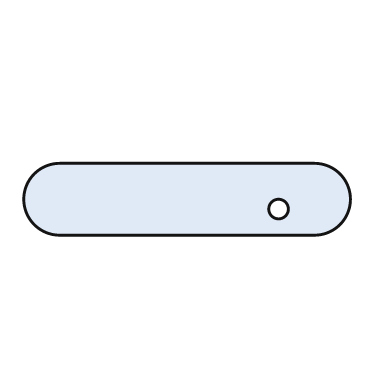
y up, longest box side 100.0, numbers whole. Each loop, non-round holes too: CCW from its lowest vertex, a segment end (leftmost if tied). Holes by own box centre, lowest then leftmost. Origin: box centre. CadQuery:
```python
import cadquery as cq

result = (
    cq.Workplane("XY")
    .moveTo(-39.0, -11.0)
    .lineTo(39.0, -11.0)
    .threePointArc((50.0, 0.0), (39.0, 11.0))
    .lineTo(-39.0, 11.0)
    .threePointArc((-50.0, 0.0), (-39.0, -11.0))
    .close()
    .moveTo(28.0, -3.0)
    .circle(3.0)
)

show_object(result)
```